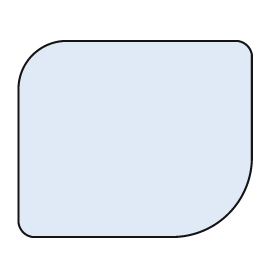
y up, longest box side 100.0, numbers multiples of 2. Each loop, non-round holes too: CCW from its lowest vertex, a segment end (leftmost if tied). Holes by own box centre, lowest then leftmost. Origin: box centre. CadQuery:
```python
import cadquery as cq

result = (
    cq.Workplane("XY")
    .moveTo(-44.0, -42.0)
    .lineTo(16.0, -42.0)
    .threePointArc((40.0, -32.0), (50.0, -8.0))
    .lineTo(50.0, 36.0)
    .threePointArc((48.0, 40.0), (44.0, 42.0))
    .lineTo(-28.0, 42.0)
    .threePointArc((-44.0, 36.0), (-50.0, 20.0))
    .lineTo(-50.0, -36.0)
    .threePointArc((-48.0, -40.0), (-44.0, -42.0))
    .close()
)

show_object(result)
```